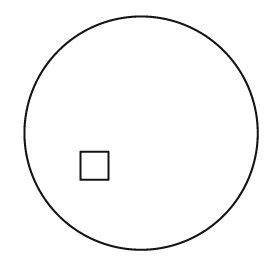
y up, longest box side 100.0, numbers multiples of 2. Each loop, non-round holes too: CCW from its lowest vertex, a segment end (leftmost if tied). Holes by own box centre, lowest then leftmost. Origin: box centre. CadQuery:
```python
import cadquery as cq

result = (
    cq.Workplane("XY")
    .moveTo(0.0, 0.0)
    .circle(50.0)
    .moveTo(-26.0, -20.0)
    .lineTo(-14.0, -20.0)
    .lineTo(-14.0, -8.0)
    .lineTo(-26.0, -8.0)
    .close()
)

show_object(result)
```